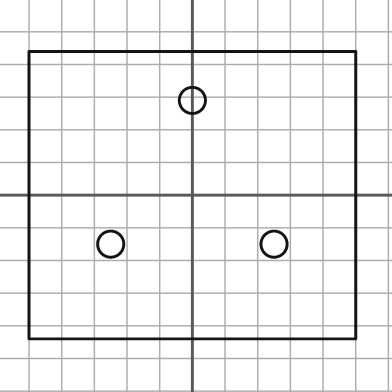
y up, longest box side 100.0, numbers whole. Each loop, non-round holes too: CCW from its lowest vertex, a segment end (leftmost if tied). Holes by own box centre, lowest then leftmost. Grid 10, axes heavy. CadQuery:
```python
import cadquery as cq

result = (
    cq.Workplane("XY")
    .moveTo(-50.0, -44.0)
    .lineTo(50.0, -44.0)
    .lineTo(50.0, 44.0)
    .lineTo(-50.0, 44.0)
    .close()
    .moveTo(-25.0, -15.0)
    .circle(4.0)
    .moveTo(25.0, -15.0)
    .circle(4.0)
    .moveTo(0.0, 29.0)
    .circle(4.0)
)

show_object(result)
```